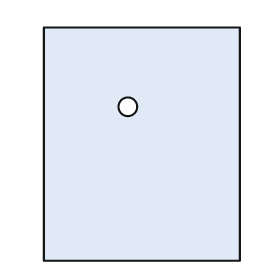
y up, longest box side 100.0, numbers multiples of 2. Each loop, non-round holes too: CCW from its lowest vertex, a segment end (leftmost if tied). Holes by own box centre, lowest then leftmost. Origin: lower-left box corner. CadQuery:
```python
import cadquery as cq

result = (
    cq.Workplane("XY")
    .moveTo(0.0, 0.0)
    .lineTo(84.0, 0.0)
    .lineTo(84.0, 100.0)
    .lineTo(0.0, 100.0)
    .close()
    .moveTo(36.0, 66.0)
    .circle(4.0)
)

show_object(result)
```